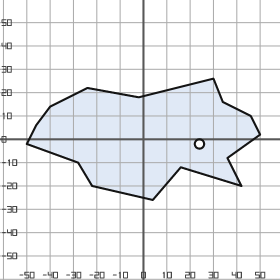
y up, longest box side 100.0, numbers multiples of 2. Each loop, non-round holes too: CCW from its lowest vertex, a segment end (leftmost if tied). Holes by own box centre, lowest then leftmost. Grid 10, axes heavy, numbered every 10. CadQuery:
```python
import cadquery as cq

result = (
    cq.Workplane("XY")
    .moveTo(4.0, -26.0)
    .lineTo(16.0, -12.0)
    .lineTo(42.0, -20.0)
    .lineTo(36.0, -8.0)
    .lineTo(50.0, 2.0)
    .lineTo(46.0, 10.0)
    .lineTo(34.0, 16.0)
    .lineTo(30.0, 26.0)
    .lineTo(-2.0, 18.0)
    .lineTo(-24.0, 22.0)
    .lineTo(-40.0, 14.0)
    .lineTo(-46.0, 6.0)
    .lineTo(-50.0, -2.0)
    .lineTo(-28.0, -10.0)
    .lineTo(-22.0, -20.0)
    .close()
    .moveTo(24.0, -2.0)
    .circle(2.0)
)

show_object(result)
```